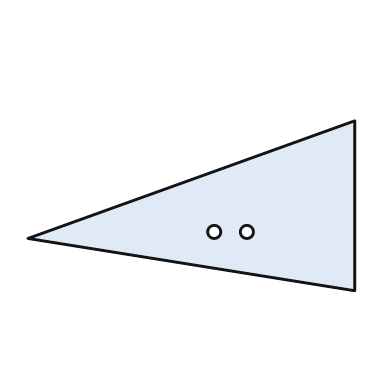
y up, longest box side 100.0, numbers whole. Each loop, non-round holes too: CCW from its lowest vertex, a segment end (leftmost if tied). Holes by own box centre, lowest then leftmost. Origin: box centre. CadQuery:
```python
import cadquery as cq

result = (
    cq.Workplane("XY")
    .moveTo(50.0, -26.0)
    .lineTo(50.0, 26.0)
    .lineTo(-50.0, -10.0)
    .close()
    .moveTo(7.0, -8.0)
    .circle(2.0)
    .moveTo(17.0, -8.0)
    .circle(2.0)
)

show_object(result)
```